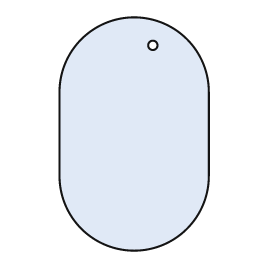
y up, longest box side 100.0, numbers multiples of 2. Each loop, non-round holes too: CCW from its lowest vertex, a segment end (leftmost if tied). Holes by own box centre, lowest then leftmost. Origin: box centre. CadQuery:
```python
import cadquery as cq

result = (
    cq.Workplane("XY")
    .moveTo(-32.0, -18.0)
    .threePointArc((0.0, -50.0), (32.0, -18.0))
    .lineTo(32.0, 18.0)
    .threePointArc((0.0, 50.0), (-32.0, 18.0))
    .close()
    .moveTo(8.0, 38.0)
    .circle(2.0)
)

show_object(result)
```